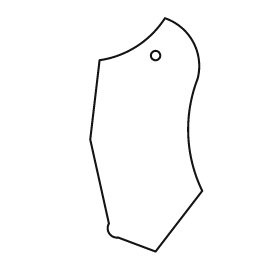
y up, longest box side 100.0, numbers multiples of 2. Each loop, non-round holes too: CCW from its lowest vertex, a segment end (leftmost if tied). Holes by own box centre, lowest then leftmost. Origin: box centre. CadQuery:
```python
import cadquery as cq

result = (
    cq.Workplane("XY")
    .moveTo(4.0, -50.0)
    .lineTo(24.0, -24.0)
    .threePointArc((18.0, 0.0), (22.0, 24.0))
    .threePointArc((20.0, 40.0), (8.0, 50.0))
    .threePointArc((-4.0, 38.0), (-20.0, 32.0))
    .lineTo(-24.0, -2.0)
    .lineTo(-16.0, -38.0)
    .threePointArc((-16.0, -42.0), (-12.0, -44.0))
    .close()
    .moveTo(4.0, 34.0)
    .circle(2.0)
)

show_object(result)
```